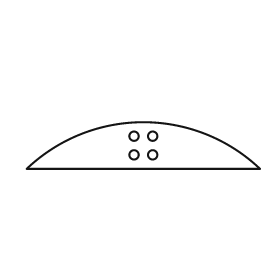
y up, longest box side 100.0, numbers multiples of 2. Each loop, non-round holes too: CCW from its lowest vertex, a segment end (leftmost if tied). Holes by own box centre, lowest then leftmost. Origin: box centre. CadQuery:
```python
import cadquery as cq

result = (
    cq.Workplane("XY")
    .moveTo(-50.0, -10.0)
    .lineTo(50.0, -10.0)
    .threePointArc((0.0, 10.0), (-50.0, -10.0))
    .close()
    .moveTo(-4.0, -4.0)
    .circle(2.0)
    .moveTo(4.0, -4.0)
    .circle(2.0)
    .moveTo(-4.0, 4.0)
    .circle(2.0)
    .moveTo(4.0, 4.0)
    .circle(2.0)
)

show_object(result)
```